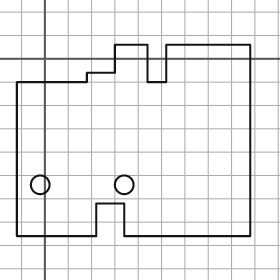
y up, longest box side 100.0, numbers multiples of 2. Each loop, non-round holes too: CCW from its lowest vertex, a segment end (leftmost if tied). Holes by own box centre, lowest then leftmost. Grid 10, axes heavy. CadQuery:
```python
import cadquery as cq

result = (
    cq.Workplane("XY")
    .moveTo(-12.0, -76.0)
    .lineTo(22.0, -76.0)
    .lineTo(22.0, -62.0)
    .lineTo(34.0, -62.0)
    .lineTo(34.0, -76.0)
    .lineTo(88.0, -76.0)
    .lineTo(88.0, 6.0)
    .lineTo(52.0, 6.0)
    .lineTo(52.0, -10.0)
    .lineTo(44.0, -10.0)
    .lineTo(44.0, 6.0)
    .lineTo(30.0, 6.0)
    .lineTo(30.0, -6.0)
    .lineTo(18.0, -6.0)
    .lineTo(18.0, -10.0)
    .lineTo(-12.0, -10.0)
    .close()
    .moveTo(-2.0, -54.0)
    .circle(4.0)
    .moveTo(34.0, -54.0)
    .circle(4.0)
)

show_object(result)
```